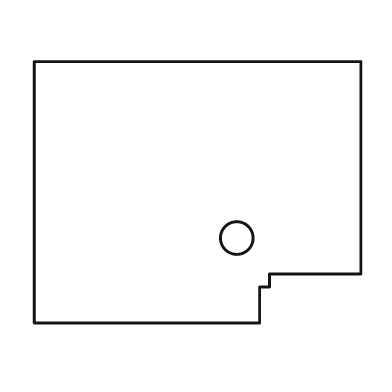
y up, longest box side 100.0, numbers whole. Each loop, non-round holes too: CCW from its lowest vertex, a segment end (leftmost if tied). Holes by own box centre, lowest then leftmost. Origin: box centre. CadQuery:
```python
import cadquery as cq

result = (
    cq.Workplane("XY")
    .moveTo(-50.0, -40.0)
    .lineTo(19.0, -40.0)
    .lineTo(19.0, -29.0)
    .lineTo(22.0, -29.0)
    .lineTo(22.0, -25.0)
    .lineTo(50.0, -25.0)
    .lineTo(50.0, 40.0)
    .lineTo(-50.0, 40.0)
    .close()
    .moveTo(12.0, -14.0)
    .circle(5.0)
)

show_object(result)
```